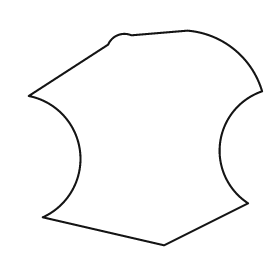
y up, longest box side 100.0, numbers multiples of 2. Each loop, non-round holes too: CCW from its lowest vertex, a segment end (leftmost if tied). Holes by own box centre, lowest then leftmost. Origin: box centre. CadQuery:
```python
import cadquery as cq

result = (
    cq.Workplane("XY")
    .moveTo(8.0, -46.0)
    .lineTo(44.0, -28.0)
    .threePointArc((32.0, -2.0), (50.0, 20.0))
    .threePointArc((38.0, 38.0), (18.0, 46.0))
    .lineTo(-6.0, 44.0)
    .threePointArc((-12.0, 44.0), (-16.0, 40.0))
    .lineTo(-50.0, 18.0)
    .threePointArc((-28.0, -6.0), (-44.0, -34.0))
    .close()
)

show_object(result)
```